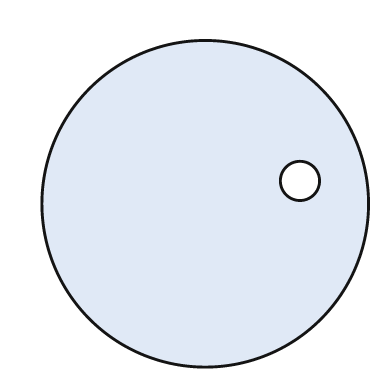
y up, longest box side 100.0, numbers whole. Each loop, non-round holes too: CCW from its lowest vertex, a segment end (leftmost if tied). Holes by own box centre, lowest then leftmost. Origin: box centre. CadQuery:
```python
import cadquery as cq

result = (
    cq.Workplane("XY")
    .moveTo(0.0, 0.0)
    .circle(50.0)
    .moveTo(29.0, 7.0)
    .circle(6.0)
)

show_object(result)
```